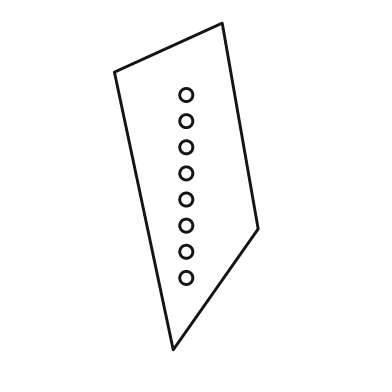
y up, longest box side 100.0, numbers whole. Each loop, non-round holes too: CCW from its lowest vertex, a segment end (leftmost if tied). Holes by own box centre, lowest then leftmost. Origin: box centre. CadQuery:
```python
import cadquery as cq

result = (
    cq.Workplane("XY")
    .moveTo(-4.0, -50.0)
    .lineTo(22.0, -13.0)
    .lineTo(11.0, 50.0)
    .lineTo(-22.0, 35.0)
    .close()
    .moveTo(0.0, -28.0)
    .circle(2.0)
    .moveTo(0.0, -20.0)
    .circle(2.0)
    .moveTo(0.0, -12.0)
    .circle(2.0)
    .moveTo(0.0, -4.0)
    .circle(2.0)
    .moveTo(0.0, 4.0)
    .circle(2.0)
    .moveTo(0.0, 12.0)
    .circle(2.0)
    .moveTo(0.0, 20.0)
    .circle(2.0)
    .moveTo(0.0, 28.0)
    .circle(2.0)
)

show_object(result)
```